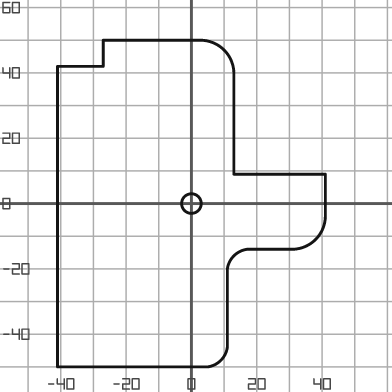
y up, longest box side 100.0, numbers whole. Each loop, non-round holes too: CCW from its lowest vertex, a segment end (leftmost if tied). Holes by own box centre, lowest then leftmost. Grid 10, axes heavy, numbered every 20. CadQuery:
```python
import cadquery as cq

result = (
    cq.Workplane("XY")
    .moveTo(-41.0, -50.0)
    .lineTo(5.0, -50.0)
    .threePointArc((9.0, -48.0), (11.0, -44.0))
    .lineTo(11.0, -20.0)
    .threePointArc((13.0, -16.0), (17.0, -14.0))
    .lineTo(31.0, -14.0)
    .threePointArc((38.0, -11.0), (41.0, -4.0))
    .lineTo(41.0, 9.0)
    .lineTo(13.0, 9.0)
    .lineTo(13.0, 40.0)
    .threePointArc((10.0, 47.0), (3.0, 50.0))
    .lineTo(-27.0, 50.0)
    .lineTo(-27.0, 42.0)
    .lineTo(-41.0, 42.0)
    .close()
    .moveTo(0.0, 0.0)
    .circle(3.0)
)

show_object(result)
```